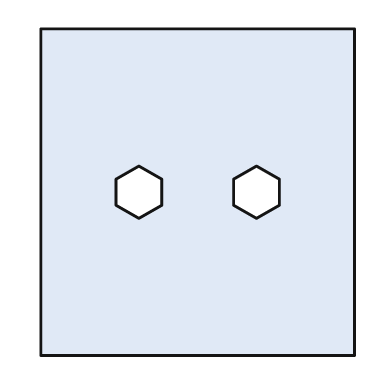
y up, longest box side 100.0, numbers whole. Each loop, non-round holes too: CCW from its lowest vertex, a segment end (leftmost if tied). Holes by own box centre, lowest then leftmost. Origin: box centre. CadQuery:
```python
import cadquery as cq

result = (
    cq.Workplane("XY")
    .moveTo(-48.0, -50.0)
    .lineTo(48.0, -50.0)
    .lineTo(48.0, 50.0)
    .lineTo(-48.0, 50.0)
    .close()
    .moveTo(-18.0, -8.0)
    .lineTo(-11.0, -4.0)
    .lineTo(-11.0, 4.0)
    .lineTo(-18.0, 8.0)
    .lineTo(-25.0, 4.0)
    .lineTo(-25.0, -4.0)
    .close()
    .moveTo(18.0, -8.0)
    .lineTo(25.0, -4.0)
    .lineTo(25.0, 4.0)
    .lineTo(18.0, 8.0)
    .lineTo(11.0, 4.0)
    .lineTo(11.0, -4.0)
    .close()
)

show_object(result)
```